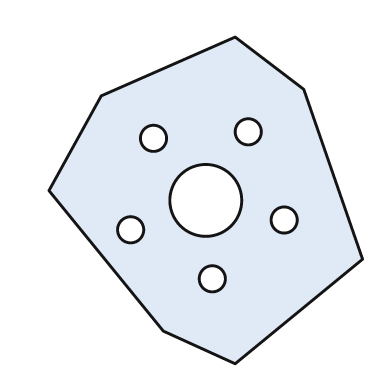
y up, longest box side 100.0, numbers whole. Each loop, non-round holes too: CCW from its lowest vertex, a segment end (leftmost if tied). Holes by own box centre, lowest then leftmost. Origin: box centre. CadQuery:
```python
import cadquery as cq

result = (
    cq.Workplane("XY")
    .moveTo(9.0, -50.0)
    .lineTo(48.0, -18.0)
    .lineTo(30.0, 34.0)
    .lineTo(9.0, 50.0)
    .lineTo(-32.0, 32.0)
    .lineTo(-48.0, 3.0)
    .lineTo(-13.0, -40.0)
    .close()
    .moveTo(2.0, -24.0)
    .circle(4.0)
    .moveTo(-23.0, -9.0)
    .circle(4.0)
    .moveTo(24.0, -6.0)
    .circle(4.0)
    .moveTo(0.0, 0.0)
    .circle(11.0)
    .moveTo(-16.0, 19.0)
    .circle(4.0)
    .moveTo(13.0, 21.0)
    .circle(4.0)
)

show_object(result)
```